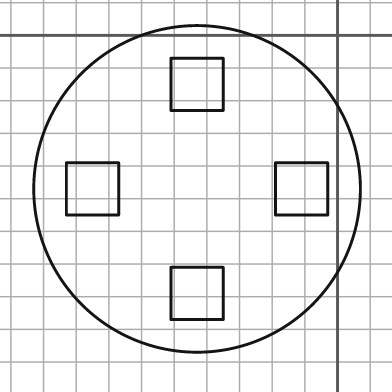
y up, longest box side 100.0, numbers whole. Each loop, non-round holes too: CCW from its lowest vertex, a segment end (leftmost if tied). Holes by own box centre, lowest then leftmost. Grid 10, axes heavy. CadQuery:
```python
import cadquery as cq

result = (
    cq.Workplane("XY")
    .moveTo(-43.0, -47.0)
    .circle(50.0)
    .moveTo(-51.0, -87.0)
    .lineTo(-35.0, -87.0)
    .lineTo(-35.0, -71.0)
    .lineTo(-51.0, -71.0)
    .close()
    .moveTo(-83.0, -55.0)
    .lineTo(-67.0, -55.0)
    .lineTo(-67.0, -39.0)
    .lineTo(-83.0, -39.0)
    .close()
    .moveTo(-19.0, -55.0)
    .lineTo(-3.0, -55.0)
    .lineTo(-3.0, -39.0)
    .lineTo(-19.0, -39.0)
    .close()
    .moveTo(-51.0, -23.0)
    .lineTo(-35.0, -23.0)
    .lineTo(-35.0, -7.0)
    .lineTo(-51.0, -7.0)
    .close()
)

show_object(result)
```